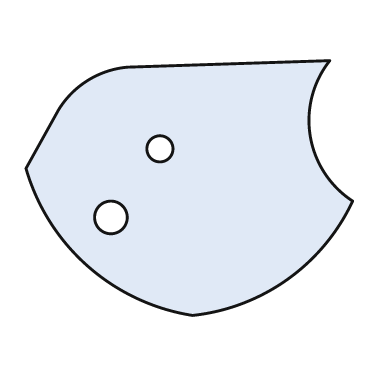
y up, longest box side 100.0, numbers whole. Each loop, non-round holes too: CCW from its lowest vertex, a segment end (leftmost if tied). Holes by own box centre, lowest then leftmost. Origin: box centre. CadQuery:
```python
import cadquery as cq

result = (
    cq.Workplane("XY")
    .moveTo(1.0, -39.0)
    .threePointArc((30.0, -28.0), (50.0, -4.0))
    .threePointArc((37.0, 16.0), (43.0, 39.0))
    .lineTo(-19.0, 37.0)
    .threePointArc((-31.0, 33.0), (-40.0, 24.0))
    .lineTo(-50.0, 6.0)
    .threePointArc((-31.0, -24.0), (1.0, -39.0))
    .close()
    .moveTo(-24.0, -9.0)
    .circle(5.0)
    .moveTo(-9.0, 12.0)
    .circle(4.0)
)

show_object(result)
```